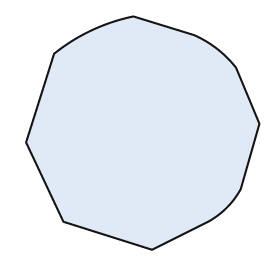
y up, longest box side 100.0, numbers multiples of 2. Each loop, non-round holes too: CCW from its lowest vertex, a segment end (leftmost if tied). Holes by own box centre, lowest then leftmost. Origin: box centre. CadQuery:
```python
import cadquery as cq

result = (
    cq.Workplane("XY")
    .moveTo(4.0, -50.0)
    .lineTo(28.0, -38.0)
    .threePointArc((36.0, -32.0), (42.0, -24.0))
    .lineTo(50.0, 4.0)
    .lineTo(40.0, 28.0)
    .threePointArc((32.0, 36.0), (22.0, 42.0))
    .lineTo(-4.0, 50.0)
    .threePointArc((-22.0, 44.0), (-38.0, 34.0))
    .lineTo(-50.0, -4.0)
    .lineTo(-34.0, -38.0)
    .close()
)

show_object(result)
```